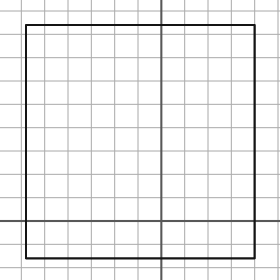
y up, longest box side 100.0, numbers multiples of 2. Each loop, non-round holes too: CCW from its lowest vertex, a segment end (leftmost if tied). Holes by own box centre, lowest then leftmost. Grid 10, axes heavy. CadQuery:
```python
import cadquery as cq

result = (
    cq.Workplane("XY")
    .moveTo(-58.0, -16.0)
    .lineTo(40.0, -16.0)
    .lineTo(40.0, 84.0)
    .lineTo(-58.0, 84.0)
    .close()
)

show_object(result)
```